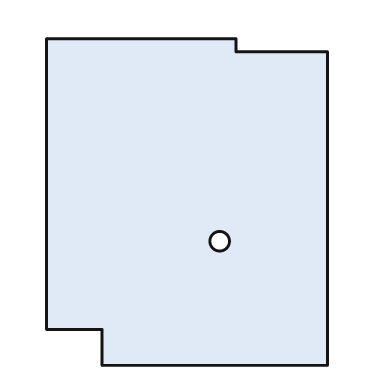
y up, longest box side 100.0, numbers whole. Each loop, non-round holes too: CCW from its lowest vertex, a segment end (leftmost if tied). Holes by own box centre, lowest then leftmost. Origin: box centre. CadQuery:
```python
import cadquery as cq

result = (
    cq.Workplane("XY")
    .moveTo(-26.0, -50.0)
    .lineTo(43.0, -50.0)
    .lineTo(43.0, 46.0)
    .lineTo(15.0, 46.0)
    .lineTo(15.0, 50.0)
    .lineTo(-43.0, 50.0)
    .lineTo(-43.0, -39.0)
    .lineTo(-26.0, -39.0)
    .close()
    .moveTo(10.0, -12.0)
    .circle(3.0)
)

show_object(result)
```